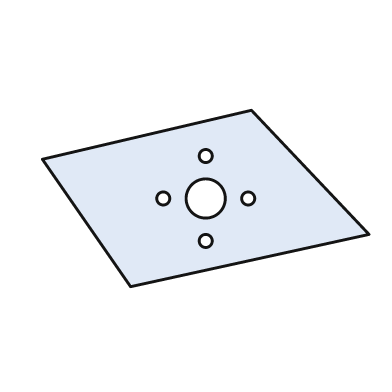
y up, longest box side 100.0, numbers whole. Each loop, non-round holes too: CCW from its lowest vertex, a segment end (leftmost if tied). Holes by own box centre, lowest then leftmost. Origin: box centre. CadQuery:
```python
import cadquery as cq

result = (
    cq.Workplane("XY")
    .moveTo(-23.0, -27.0)
    .lineTo(50.0, -11.0)
    .lineTo(14.0, 27.0)
    .lineTo(-50.0, 12.0)
    .close()
    .moveTo(0.0, -13.0)
    .circle(2.0)
    .moveTo(-13.0, 0.0)
    .circle(2.0)
    .moveTo(0.0, 0.0)
    .circle(6.0)
    .moveTo(13.0, 0.0)
    .circle(2.0)
    .moveTo(0.0, 13.0)
    .circle(2.0)
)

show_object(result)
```